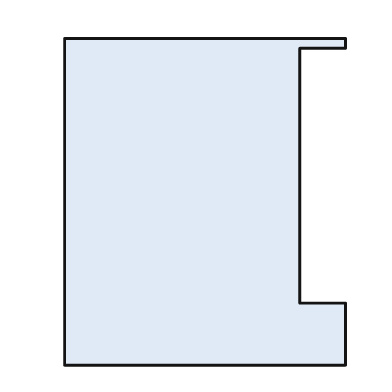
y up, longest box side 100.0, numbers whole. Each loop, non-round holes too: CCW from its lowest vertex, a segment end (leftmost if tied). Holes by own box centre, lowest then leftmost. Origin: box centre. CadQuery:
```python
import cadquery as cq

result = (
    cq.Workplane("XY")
    .moveTo(-43.0, -50.0)
    .lineTo(43.0, -50.0)
    .lineTo(43.0, -31.0)
    .lineTo(29.0, -31.0)
    .lineTo(29.0, 47.0)
    .lineTo(43.0, 47.0)
    .lineTo(43.0, 50.0)
    .lineTo(-43.0, 50.0)
    .close()
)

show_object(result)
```